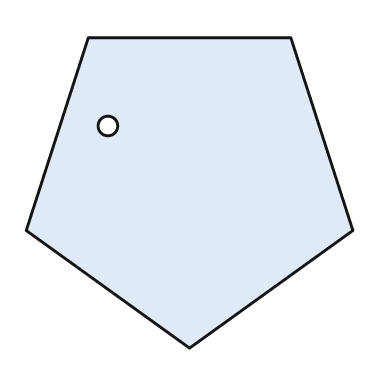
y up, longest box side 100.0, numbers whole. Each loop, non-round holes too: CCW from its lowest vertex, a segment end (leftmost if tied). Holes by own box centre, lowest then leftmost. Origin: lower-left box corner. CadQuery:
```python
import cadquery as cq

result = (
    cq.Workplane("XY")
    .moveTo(50.0, 0.0)
    .lineTo(100.0, 36.0)
    .lineTo(81.0, 95.0)
    .lineTo(19.0, 95.0)
    .lineTo(0.0, 36.0)
    .close()
    .moveTo(25.0, 68.0)
    .circle(3.0)
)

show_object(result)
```